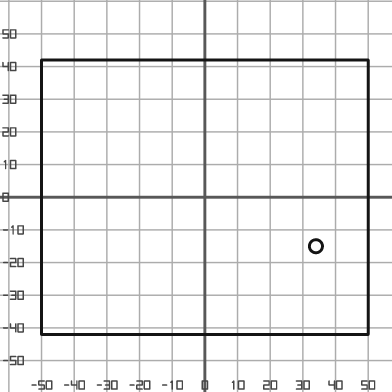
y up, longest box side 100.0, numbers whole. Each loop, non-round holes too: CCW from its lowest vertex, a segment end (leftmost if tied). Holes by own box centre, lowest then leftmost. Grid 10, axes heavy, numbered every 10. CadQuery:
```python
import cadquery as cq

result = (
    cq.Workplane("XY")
    .moveTo(-50.0, -42.0)
    .lineTo(50.0, -42.0)
    .lineTo(50.0, 42.0)
    .lineTo(-50.0, 42.0)
    .close()
    .moveTo(34.0, -15.0)
    .circle(2.0)
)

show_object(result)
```